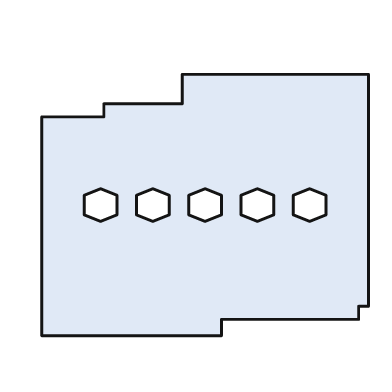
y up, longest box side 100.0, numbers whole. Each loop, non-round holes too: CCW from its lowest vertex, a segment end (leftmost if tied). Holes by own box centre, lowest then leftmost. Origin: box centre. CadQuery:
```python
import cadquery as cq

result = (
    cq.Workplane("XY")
    .moveTo(-50.0, -40.0)
    .lineTo(5.0, -40.0)
    .lineTo(5.0, -35.0)
    .lineTo(47.0, -35.0)
    .lineTo(47.0, -31.0)
    .lineTo(50.0, -31.0)
    .lineTo(50.0, 40.0)
    .lineTo(-7.0, 40.0)
    .lineTo(-7.0, 31.0)
    .lineTo(-31.0, 31.0)
    .lineTo(-31.0, 27.0)
    .lineTo(-50.0, 27.0)
    .close()
    .moveTo(-32.0, -5.0)
    .lineTo(-27.0, -3.0)
    .lineTo(-27.0, 3.0)
    .lineTo(-32.0, 5.0)
    .lineTo(-37.0, 3.0)
    .lineTo(-37.0, -3.0)
    .close()
    .moveTo(-16.0, -5.0)
    .lineTo(-11.0, -3.0)
    .lineTo(-11.0, 3.0)
    .lineTo(-16.0, 5.0)
    .lineTo(-21.0, 3.0)
    .lineTo(-21.0, -3.0)
    .close()
    .moveTo(0.0, -5.0)
    .lineTo(5.0, -3.0)
    .lineTo(5.0, 3.0)
    .lineTo(0.0, 5.0)
    .lineTo(-5.0, 3.0)
    .lineTo(-5.0, -3.0)
    .close()
    .moveTo(16.0, -5.0)
    .lineTo(21.0, -3.0)
    .lineTo(21.0, 3.0)
    .lineTo(16.0, 5.0)
    .lineTo(11.0, 3.0)
    .lineTo(11.0, -3.0)
    .close()
    .moveTo(32.0, -5.0)
    .lineTo(37.0, -3.0)
    .lineTo(37.0, 3.0)
    .lineTo(32.0, 5.0)
    .lineTo(27.0, 3.0)
    .lineTo(27.0, -3.0)
    .close()
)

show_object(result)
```